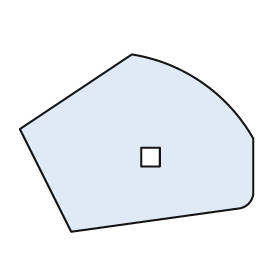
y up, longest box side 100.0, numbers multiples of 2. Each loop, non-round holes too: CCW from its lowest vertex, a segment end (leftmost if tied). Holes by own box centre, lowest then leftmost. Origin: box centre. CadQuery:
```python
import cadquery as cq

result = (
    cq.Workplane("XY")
    .moveTo(-28.0, -38.0)
    .lineTo(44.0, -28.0)
    .threePointArc((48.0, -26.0), (50.0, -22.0))
    .lineTo(50.0, 2.0)
    .threePointArc((28.0, 26.0), (-2.0, 38.0))
    .lineTo(-50.0, 6.0)
    .close()
    .moveTo(2.0, -10.0)
    .lineTo(10.0, -10.0)
    .lineTo(10.0, -2.0)
    .lineTo(2.0, -2.0)
    .close()
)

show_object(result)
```